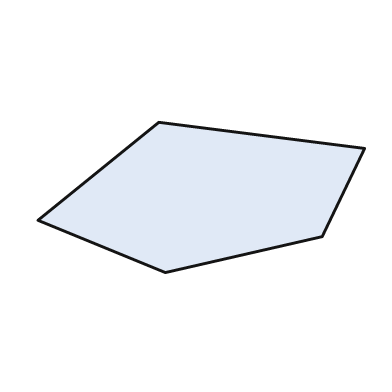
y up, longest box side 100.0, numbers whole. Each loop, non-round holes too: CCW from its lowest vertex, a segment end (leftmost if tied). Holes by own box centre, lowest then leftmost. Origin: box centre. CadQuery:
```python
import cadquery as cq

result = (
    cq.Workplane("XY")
    .moveTo(-11.0, -23.0)
    .lineTo(37.0, -12.0)
    .lineTo(50.0, 15.0)
    .lineTo(-13.0, 23.0)
    .lineTo(-50.0, -7.0)
    .close()
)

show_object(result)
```